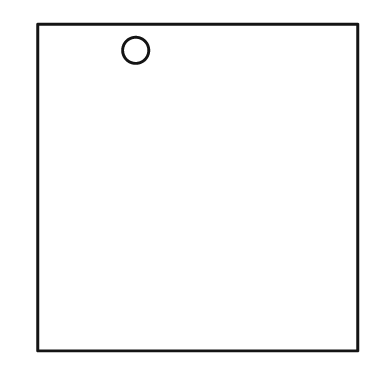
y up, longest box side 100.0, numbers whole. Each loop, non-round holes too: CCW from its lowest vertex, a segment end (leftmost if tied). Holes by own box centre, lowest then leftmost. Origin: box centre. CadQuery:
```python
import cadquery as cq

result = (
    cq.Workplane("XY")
    .moveTo(-49.0, -50.0)
    .lineTo(49.0, -50.0)
    .lineTo(49.0, 50.0)
    .lineTo(-49.0, 50.0)
    .close()
    .moveTo(-19.0, 42.0)
    .circle(4.0)
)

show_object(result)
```